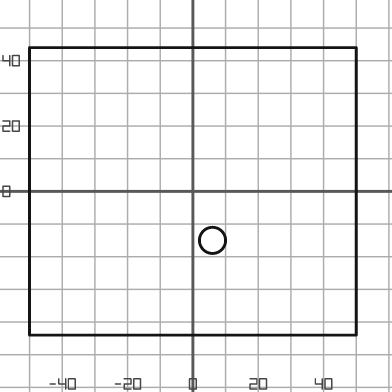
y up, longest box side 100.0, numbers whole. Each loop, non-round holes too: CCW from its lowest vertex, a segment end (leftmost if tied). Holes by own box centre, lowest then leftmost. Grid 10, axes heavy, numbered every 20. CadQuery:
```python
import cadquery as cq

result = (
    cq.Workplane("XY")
    .moveTo(-50.0, -44.0)
    .lineTo(50.0, -44.0)
    .lineTo(50.0, 44.0)
    .lineTo(-50.0, 44.0)
    .close()
    .moveTo(6.0, -15.0)
    .circle(4.0)
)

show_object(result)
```